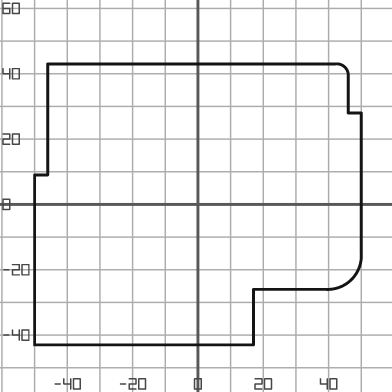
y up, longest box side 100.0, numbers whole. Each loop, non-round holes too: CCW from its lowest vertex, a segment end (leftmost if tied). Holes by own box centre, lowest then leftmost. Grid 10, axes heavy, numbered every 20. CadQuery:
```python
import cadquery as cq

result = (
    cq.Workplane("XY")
    .moveTo(-50.0, -43.0)
    .lineTo(17.0, -43.0)
    .lineTo(17.0, -26.0)
    .lineTo(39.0, -26.0)
    .threePointArc((47.0, -23.0), (50.0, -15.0))
    .lineTo(50.0, 28.0)
    .lineTo(46.0, 28.0)
    .lineTo(46.0, 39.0)
    .threePointArc((45.0, 42.0), (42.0, 43.0))
    .lineTo(-46.0, 43.0)
    .lineTo(-46.0, 9.0)
    .lineTo(-50.0, 9.0)
    .close()
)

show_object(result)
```